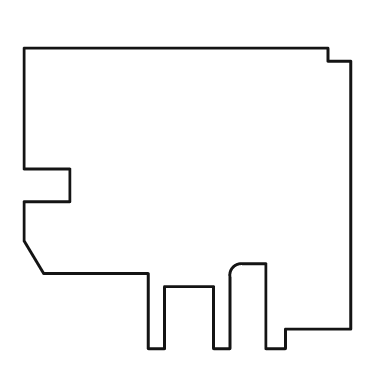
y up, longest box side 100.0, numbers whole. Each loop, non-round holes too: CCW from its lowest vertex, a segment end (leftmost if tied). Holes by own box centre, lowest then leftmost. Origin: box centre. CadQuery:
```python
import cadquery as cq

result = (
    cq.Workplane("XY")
    .moveTo(-12.0, -46.0)
    .lineTo(-7.0, -46.0)
    .lineTo(-7.0, -27.0)
    .lineTo(8.0, -27.0)
    .lineTo(8.0, -46.0)
    .lineTo(13.0, -46.0)
    .lineTo(13.0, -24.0)
    .threePointArc((14.0, -21.0), (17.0, -20.0))
    .lineTo(24.0, -20.0)
    .lineTo(24.0, -46.0)
    .lineTo(30.0, -46.0)
    .lineTo(30.0, -40.0)
    .lineTo(50.0, -40.0)
    .lineTo(50.0, 42.0)
    .lineTo(43.0, 42.0)
    .lineTo(43.0, 46.0)
    .lineTo(-50.0, 46.0)
    .lineTo(-50.0, 9.0)
    .lineTo(-36.0, 9.0)
    .lineTo(-36.0, -1.0)
    .lineTo(-50.0, -1.0)
    .lineTo(-50.0, -13.0)
    .lineTo(-44.0, -23.0)
    .lineTo(-12.0, -23.0)
    .close()
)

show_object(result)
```